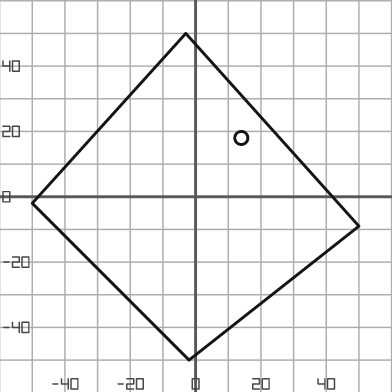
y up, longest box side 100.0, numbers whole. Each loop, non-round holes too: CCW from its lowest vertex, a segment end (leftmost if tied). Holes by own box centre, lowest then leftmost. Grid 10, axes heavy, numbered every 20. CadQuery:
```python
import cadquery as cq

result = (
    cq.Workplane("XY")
    .moveTo(-2.0, -50.0)
    .lineTo(50.0, -9.0)
    .lineTo(-3.0, 50.0)
    .lineTo(-50.0, -2.0)
    .close()
    .moveTo(14.0, 18.0)
    .circle(2.0)
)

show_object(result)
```